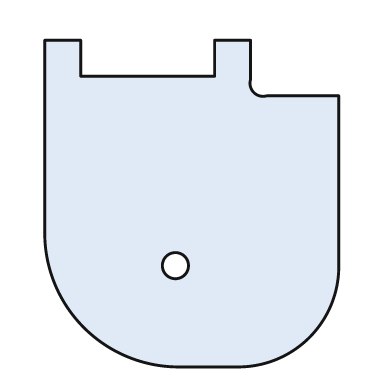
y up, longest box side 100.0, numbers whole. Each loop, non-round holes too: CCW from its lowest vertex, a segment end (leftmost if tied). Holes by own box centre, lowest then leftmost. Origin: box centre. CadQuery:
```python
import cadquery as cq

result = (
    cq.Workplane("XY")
    .moveTo(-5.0, -50.0)
    .lineTo(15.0, -50.0)
    .threePointArc((36.0, -41.0), (45.0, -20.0))
    .lineTo(45.0, 33.0)
    .lineTo(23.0, 33.0)
    .threePointArc((19.0, 34.0), (18.0, 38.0))
    .lineTo(18.0, 50.0)
    .lineTo(7.0, 50.0)
    .lineTo(7.0, 39.0)
    .lineTo(-34.0, 39.0)
    .lineTo(-34.0, 50.0)
    .lineTo(-45.0, 50.0)
    .lineTo(-45.0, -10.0)
    .threePointArc((-33.0, -38.0), (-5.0, -50.0))
    .close()
    .moveTo(-5.0, -19.0)
    .circle(4.0)
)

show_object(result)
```